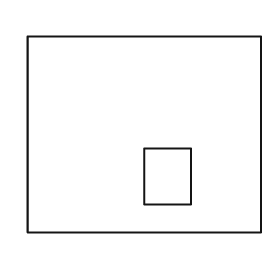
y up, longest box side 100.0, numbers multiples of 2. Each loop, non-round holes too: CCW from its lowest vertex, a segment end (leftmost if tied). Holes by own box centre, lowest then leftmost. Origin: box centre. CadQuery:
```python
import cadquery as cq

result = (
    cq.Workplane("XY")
    .moveTo(-50.0, -42.0)
    .lineTo(50.0, -42.0)
    .lineTo(50.0, 42.0)
    .lineTo(-50.0, 42.0)
    .close()
    .moveTo(0.0, -30.0)
    .lineTo(20.0, -30.0)
    .lineTo(20.0, -6.0)
    .lineTo(0.0, -6.0)
    .close()
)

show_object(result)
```